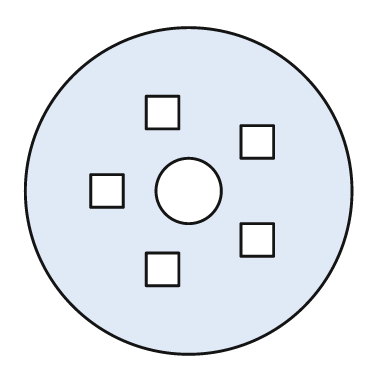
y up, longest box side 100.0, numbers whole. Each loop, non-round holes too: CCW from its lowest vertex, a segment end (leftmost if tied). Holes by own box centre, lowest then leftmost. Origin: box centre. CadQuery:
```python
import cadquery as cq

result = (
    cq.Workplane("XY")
    .moveTo(0.0, 0.0)
    .circle(50.0)
    .moveTo(-13.0, -29.0)
    .lineTo(-3.0, -29.0)
    .lineTo(-3.0, -19.0)
    .lineTo(-13.0, -19.0)
    .close()
    .moveTo(16.0, -20.0)
    .lineTo(26.0, -20.0)
    .lineTo(26.0, -10.0)
    .lineTo(16.0, -10.0)
    .close()
    .moveTo(-30.0, -5.0)
    .lineTo(-20.0, -5.0)
    .lineTo(-20.0, 5.0)
    .lineTo(-30.0, 5.0)
    .close()
    .moveTo(0.0, 0.0)
    .circle(10.0)
    .moveTo(16.0, 10.0)
    .lineTo(26.0, 10.0)
    .lineTo(26.0, 20.0)
    .lineTo(16.0, 20.0)
    .close()
    .moveTo(-13.0, 19.0)
    .lineTo(-3.0, 19.0)
    .lineTo(-3.0, 29.0)
    .lineTo(-13.0, 29.0)
    .close()
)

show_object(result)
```